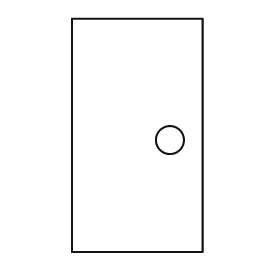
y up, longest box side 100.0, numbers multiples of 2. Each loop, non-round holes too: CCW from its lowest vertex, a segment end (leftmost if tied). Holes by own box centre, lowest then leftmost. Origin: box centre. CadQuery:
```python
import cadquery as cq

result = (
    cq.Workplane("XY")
    .moveTo(-28.0, -50.0)
    .lineTo(28.0, -50.0)
    .lineTo(28.0, 50.0)
    .lineTo(-28.0, 50.0)
    .close()
    .moveTo(14.0, -2.0)
    .circle(6.0)
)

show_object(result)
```